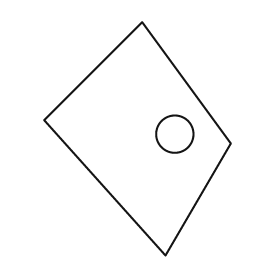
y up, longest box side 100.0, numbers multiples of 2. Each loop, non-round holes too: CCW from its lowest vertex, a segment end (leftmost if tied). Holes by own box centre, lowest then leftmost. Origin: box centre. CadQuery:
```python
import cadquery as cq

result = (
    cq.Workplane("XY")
    .moveTo(12.0, -50.0)
    .lineTo(40.0, -2.0)
    .lineTo(2.0, 50.0)
    .lineTo(-40.0, 8.0)
    .close()
    .moveTo(16.0, 2.0)
    .circle(8.0)
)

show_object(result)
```